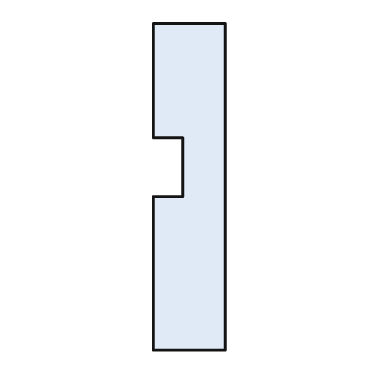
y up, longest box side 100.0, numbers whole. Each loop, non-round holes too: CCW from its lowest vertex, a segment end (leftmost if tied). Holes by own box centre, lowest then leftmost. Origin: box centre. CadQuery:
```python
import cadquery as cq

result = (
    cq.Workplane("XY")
    .moveTo(-11.0, -50.0)
    .lineTo(11.0, -50.0)
    .lineTo(11.0, 50.0)
    .lineTo(-11.0, 50.0)
    .lineTo(-11.0, 15.0)
    .lineTo(-2.0, 15.0)
    .lineTo(-2.0, -3.0)
    .lineTo(-11.0, -3.0)
    .close()
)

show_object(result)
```